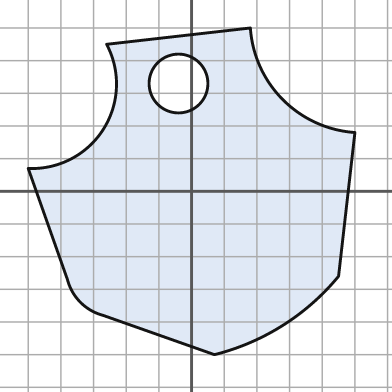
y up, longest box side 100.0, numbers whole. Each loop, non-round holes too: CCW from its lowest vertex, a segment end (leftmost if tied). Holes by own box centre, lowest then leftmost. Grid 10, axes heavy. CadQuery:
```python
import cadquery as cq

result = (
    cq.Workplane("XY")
    .moveTo(7.0, -50.0)
    .threePointArc((28.0, -41.0), (45.0, -26.0))
    .lineTo(50.0, 18.0)
    .threePointArc((28.0, 28.0), (18.0, 50.0))
    .lineTo(-26.0, 45.0)
    .threePointArc((-27.0, 19.0), (-50.0, 7.0))
    .lineTo(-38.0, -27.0)
    .threePointArc((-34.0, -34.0), (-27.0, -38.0))
    .close()
    .moveTo(-4.0, 33.0)
    .circle(9.0)
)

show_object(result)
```